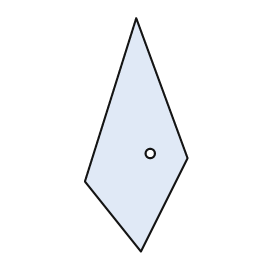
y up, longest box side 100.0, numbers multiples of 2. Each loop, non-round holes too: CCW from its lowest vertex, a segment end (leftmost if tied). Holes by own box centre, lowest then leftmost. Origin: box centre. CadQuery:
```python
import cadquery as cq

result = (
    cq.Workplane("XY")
    .moveTo(2.0, -50.0)
    .lineTo(22.0, -10.0)
    .lineTo(0.0, 50.0)
    .lineTo(-22.0, -20.0)
    .close()
    .moveTo(6.0, -8.0)
    .circle(2.0)
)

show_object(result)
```